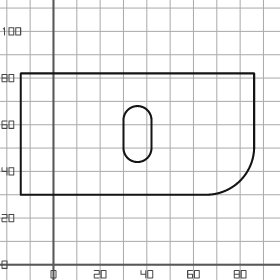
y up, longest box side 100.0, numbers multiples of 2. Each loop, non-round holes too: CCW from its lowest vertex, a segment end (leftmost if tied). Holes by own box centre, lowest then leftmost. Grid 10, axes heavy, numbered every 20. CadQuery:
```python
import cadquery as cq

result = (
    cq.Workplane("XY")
    .moveTo(-14.0, 30.0)
    .lineTo(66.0, 30.0)
    .threePointArc((80.0, 36.0), (86.0, 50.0))
    .lineTo(86.0, 82.0)
    .lineTo(-14.0, 82.0)
    .close()
    .moveTo(30.0, 50.0)
    .threePointArc((36.0, 44.0), (42.0, 50.0))
    .lineTo(42.0, 62.0)
    .threePointArc((36.0, 68.0), (30.0, 62.0))
    .close()
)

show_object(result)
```